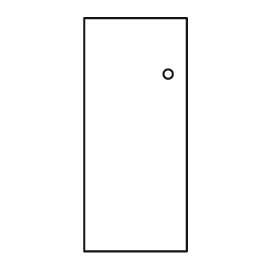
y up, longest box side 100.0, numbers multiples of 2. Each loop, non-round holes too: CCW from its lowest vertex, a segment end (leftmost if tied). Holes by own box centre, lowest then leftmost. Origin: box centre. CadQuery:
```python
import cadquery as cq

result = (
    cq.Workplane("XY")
    .moveTo(-22.0, -50.0)
    .lineTo(22.0, -50.0)
    .lineTo(22.0, 50.0)
    .lineTo(-22.0, 50.0)
    .close()
    .moveTo(14.0, 26.0)
    .circle(2.0)
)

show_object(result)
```